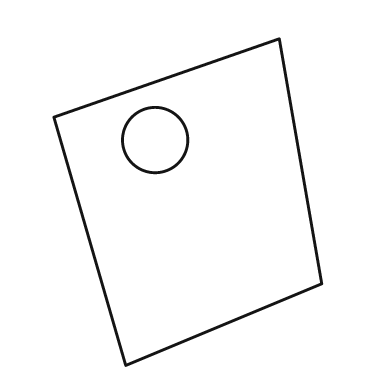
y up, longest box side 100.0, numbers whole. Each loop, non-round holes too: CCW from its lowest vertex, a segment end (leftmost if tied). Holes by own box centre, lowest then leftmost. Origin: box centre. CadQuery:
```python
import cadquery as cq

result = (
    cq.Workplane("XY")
    .moveTo(-19.0, -50.0)
    .lineTo(41.0, -25.0)
    .lineTo(28.0, 50.0)
    .lineTo(-41.0, 26.0)
    .close()
    .moveTo(-10.0, 19.0)
    .circle(10.0)
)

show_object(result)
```